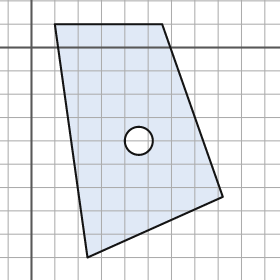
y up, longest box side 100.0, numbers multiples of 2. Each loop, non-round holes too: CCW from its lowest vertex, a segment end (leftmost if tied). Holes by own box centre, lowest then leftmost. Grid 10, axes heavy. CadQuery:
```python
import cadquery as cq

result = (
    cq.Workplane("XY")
    .moveTo(24.0, -90.0)
    .lineTo(82.0, -64.0)
    .lineTo(56.0, 10.0)
    .lineTo(10.0, 10.0)
    .close()
    .moveTo(46.0, -40.0)
    .circle(6.0)
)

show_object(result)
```